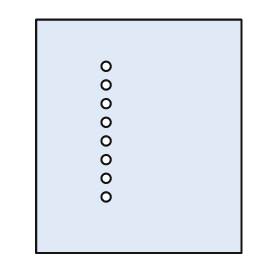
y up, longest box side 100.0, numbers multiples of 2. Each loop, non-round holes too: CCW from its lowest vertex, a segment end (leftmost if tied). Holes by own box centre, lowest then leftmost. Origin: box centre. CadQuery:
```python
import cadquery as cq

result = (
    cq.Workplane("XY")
    .moveTo(-44.0, -50.0)
    .lineTo(44.0, -50.0)
    .lineTo(44.0, 50.0)
    .lineTo(-44.0, 50.0)
    .close()
    .moveTo(-14.0, -26.0)
    .circle(2.0)
    .moveTo(-14.0, -18.0)
    .circle(2.0)
    .moveTo(-14.0, -10.0)
    .circle(2.0)
    .moveTo(-14.0, -2.0)
    .circle(2.0)
    .moveTo(-14.0, 6.0)
    .circle(2.0)
    .moveTo(-14.0, 14.0)
    .circle(2.0)
    .moveTo(-14.0, 22.0)
    .circle(2.0)
    .moveTo(-14.0, 30.0)
    .circle(2.0)
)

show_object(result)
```